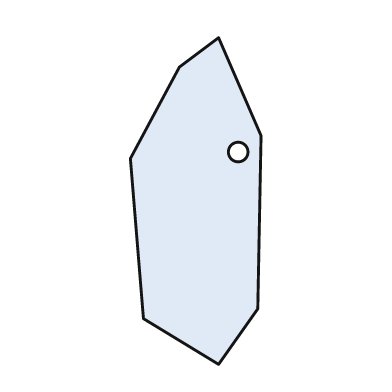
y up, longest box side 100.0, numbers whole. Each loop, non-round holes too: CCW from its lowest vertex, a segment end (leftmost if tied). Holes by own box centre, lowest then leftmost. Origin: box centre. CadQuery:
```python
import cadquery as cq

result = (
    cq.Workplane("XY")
    .moveTo(7.0, -50.0)
    .lineTo(19.0, -33.0)
    .lineTo(20.0, 20.0)
    .lineTo(7.0, 50.0)
    .lineTo(-5.0, 41.0)
    .lineTo(-20.0, 13.0)
    .lineTo(-16.0, -36.0)
    .close()
    .moveTo(13.0, 15.0)
    .circle(3.0)
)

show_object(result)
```